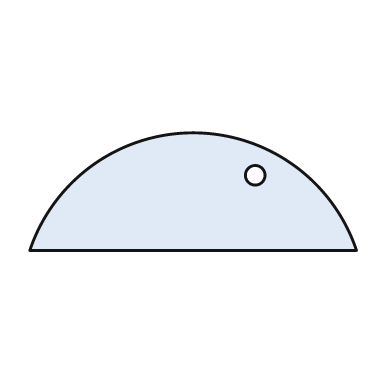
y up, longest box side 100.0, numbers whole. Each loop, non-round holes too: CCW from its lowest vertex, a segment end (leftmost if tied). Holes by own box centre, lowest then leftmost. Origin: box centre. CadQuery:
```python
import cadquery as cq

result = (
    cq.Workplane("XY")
    .moveTo(-50.0, -18.0)
    .lineTo(50.0, -18.0)
    .threePointArc((0.0, 18.0), (-50.0, -18.0))
    .close()
    .moveTo(19.0, 5.0)
    .circle(3.0)
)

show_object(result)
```